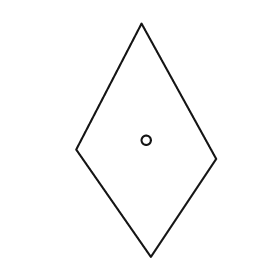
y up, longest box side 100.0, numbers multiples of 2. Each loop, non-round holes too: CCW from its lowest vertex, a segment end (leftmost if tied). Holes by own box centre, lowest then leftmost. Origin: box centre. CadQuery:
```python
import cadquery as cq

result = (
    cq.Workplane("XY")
    .moveTo(2.0, -50.0)
    .lineTo(30.0, -8.0)
    .lineTo(-2.0, 50.0)
    .lineTo(-30.0, -4.0)
    .close()
    .moveTo(0.0, 0.0)
    .circle(2.0)
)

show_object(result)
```